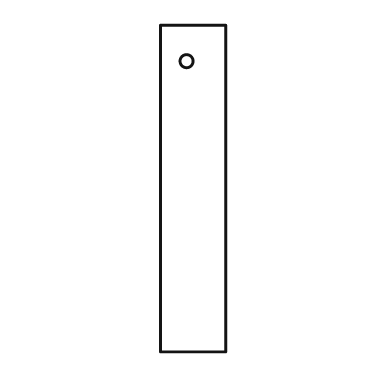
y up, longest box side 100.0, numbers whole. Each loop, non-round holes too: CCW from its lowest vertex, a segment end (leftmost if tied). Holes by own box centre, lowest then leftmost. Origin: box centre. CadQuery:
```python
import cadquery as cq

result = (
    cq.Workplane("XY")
    .moveTo(-10.0, -50.0)
    .lineTo(10.0, -50.0)
    .lineTo(10.0, 50.0)
    .lineTo(-10.0, 50.0)
    .close()
    .moveTo(-2.0, 39.0)
    .circle(2.0)
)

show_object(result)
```